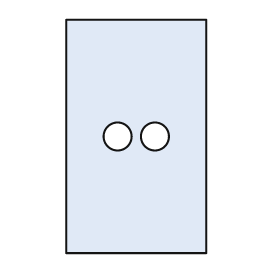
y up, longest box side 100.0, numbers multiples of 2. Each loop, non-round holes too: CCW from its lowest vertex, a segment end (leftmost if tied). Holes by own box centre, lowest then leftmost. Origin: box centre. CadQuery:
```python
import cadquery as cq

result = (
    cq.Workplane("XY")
    .moveTo(-30.0, -50.0)
    .lineTo(30.0, -50.0)
    .lineTo(30.0, 50.0)
    .lineTo(-30.0, 50.0)
    .close()
    .moveTo(-8.0, 0.0)
    .circle(6.0)
    .moveTo(8.0, 0.0)
    .circle(6.0)
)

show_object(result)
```